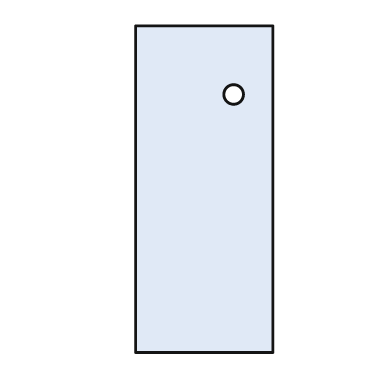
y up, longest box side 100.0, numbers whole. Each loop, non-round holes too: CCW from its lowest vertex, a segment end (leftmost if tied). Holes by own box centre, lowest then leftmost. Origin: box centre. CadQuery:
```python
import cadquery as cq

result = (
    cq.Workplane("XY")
    .moveTo(-21.0, -50.0)
    .lineTo(21.0, -50.0)
    .lineTo(21.0, 50.0)
    .lineTo(-21.0, 50.0)
    .close()
    .moveTo(9.0, 29.0)
    .circle(3.0)
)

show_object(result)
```